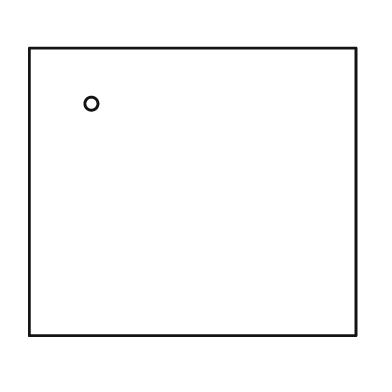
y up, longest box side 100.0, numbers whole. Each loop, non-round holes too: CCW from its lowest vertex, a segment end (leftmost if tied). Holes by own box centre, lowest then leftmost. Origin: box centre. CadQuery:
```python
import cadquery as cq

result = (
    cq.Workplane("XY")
    .moveTo(-50.0, -44.0)
    .lineTo(50.0, -44.0)
    .lineTo(50.0, 44.0)
    .lineTo(-50.0, 44.0)
    .close()
    .moveTo(-31.0, 27.0)
    .circle(2.0)
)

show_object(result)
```